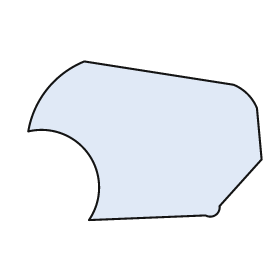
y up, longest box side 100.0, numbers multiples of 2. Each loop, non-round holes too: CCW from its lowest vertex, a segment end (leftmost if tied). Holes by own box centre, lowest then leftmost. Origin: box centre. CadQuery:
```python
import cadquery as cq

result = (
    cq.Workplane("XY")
    .moveTo(-24.0, -34.0)
    .lineTo(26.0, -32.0)
    .threePointArc((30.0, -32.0), (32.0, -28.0))
    .lineTo(50.0, -8.0)
    .lineTo(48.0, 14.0)
    .threePointArc((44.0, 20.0), (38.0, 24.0))
    .lineTo(-26.0, 34.0)
    .threePointArc((-42.0, 22.0), (-50.0, 4.0))
    .threePointArc((-24.0, -6.0), (-24.0, -34.0))
    .close()
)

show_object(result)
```